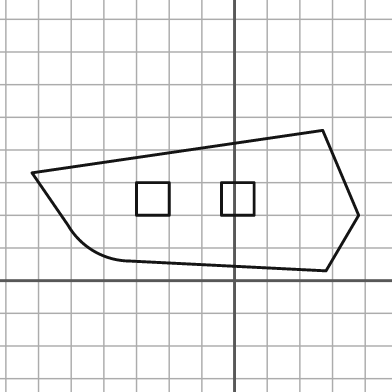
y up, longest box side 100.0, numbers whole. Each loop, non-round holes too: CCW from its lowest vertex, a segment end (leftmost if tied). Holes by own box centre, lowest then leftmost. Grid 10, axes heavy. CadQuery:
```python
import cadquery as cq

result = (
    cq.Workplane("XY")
    .moveTo(28.0, 3.0)
    .lineTo(38.0, 20.0)
    .lineTo(27.0, 46.0)
    .lineTo(-62.0, 33.0)
    .lineTo(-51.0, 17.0)
    .threePointArc((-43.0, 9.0), (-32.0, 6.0))
    .close()
    .moveTo(-30.0, 20.0)
    .lineTo(-20.0, 20.0)
    .lineTo(-20.0, 30.0)
    .lineTo(-30.0, 30.0)
    .close()
    .moveTo(-4.0, 20.0)
    .lineTo(6.0, 20.0)
    .lineTo(6.0, 30.0)
    .lineTo(-4.0, 30.0)
    .close()
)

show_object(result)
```